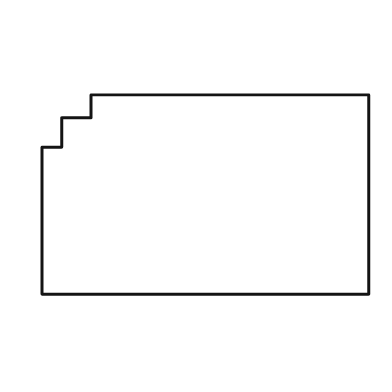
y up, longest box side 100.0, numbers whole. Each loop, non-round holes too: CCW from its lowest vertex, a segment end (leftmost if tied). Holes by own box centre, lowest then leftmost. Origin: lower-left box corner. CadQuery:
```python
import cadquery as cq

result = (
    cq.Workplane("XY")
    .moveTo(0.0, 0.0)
    .lineTo(100.0, 0.0)
    .lineTo(100.0, 61.0)
    .lineTo(15.0, 61.0)
    .lineTo(15.0, 54.0)
    .lineTo(6.0, 54.0)
    .lineTo(6.0, 45.0)
    .lineTo(0.0, 45.0)
    .close()
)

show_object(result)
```